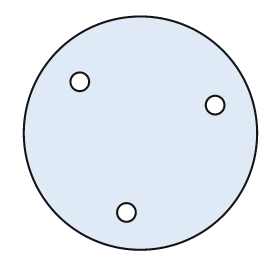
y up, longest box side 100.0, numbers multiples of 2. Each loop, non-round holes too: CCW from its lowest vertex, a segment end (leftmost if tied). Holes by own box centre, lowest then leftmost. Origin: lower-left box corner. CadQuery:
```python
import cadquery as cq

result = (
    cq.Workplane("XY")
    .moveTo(50.0, 50.0)
    .circle(50.0)
    .moveTo(44.0, 16.0)
    .circle(4.0)
    .moveTo(82.0, 62.0)
    .circle(4.0)
    .moveTo(24.0, 72.0)
    .circle(4.0)
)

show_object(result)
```